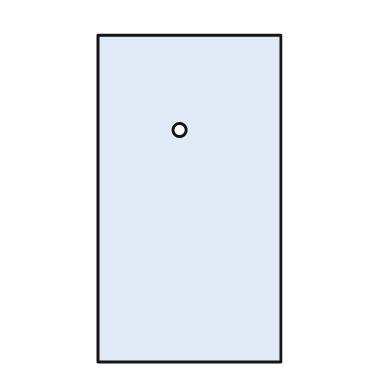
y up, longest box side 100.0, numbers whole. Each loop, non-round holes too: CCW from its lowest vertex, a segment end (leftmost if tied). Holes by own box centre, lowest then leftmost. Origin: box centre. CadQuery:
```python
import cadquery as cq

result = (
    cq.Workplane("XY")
    .moveTo(-28.0, -50.0)
    .lineTo(28.0, -50.0)
    .lineTo(28.0, 50.0)
    .lineTo(-28.0, 50.0)
    .close()
    .moveTo(-3.0, 21.0)
    .circle(2.0)
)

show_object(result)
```